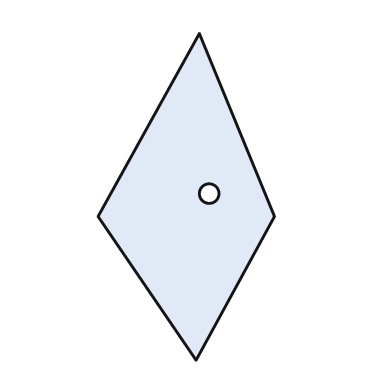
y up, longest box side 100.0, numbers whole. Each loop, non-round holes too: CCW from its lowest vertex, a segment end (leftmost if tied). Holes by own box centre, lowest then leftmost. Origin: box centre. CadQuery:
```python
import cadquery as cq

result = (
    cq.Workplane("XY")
    .moveTo(3.0, -50.0)
    .lineTo(27.0, -6.0)
    .lineTo(4.0, 50.0)
    .lineTo(-27.0, -6.0)
    .close()
    .moveTo(7.0, 1.0)
    .circle(3.0)
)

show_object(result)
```